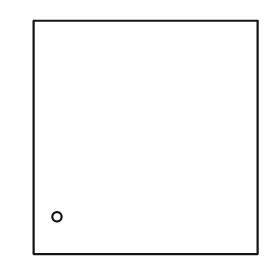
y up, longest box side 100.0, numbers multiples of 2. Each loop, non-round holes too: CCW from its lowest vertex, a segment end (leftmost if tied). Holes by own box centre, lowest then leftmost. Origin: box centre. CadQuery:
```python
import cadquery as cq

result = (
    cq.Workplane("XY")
    .moveTo(-48.0, -50.0)
    .lineTo(48.0, -50.0)
    .lineTo(48.0, 50.0)
    .lineTo(-48.0, 50.0)
    .close()
    .moveTo(-38.0, -34.0)
    .circle(2.0)
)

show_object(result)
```